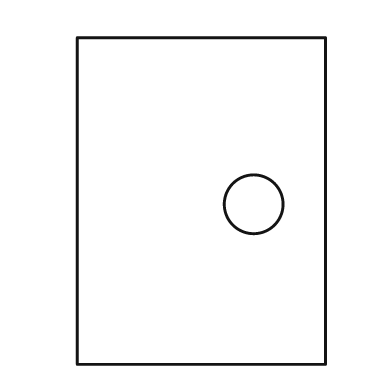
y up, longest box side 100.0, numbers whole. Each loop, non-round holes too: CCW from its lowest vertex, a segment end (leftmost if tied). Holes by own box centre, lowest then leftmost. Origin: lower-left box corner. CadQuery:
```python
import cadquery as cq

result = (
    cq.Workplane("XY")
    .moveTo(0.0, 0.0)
    .lineTo(76.0, 0.0)
    .lineTo(76.0, 100.0)
    .lineTo(0.0, 100.0)
    .close()
    .moveTo(54.0, 49.0)
    .circle(9.0)
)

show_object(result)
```